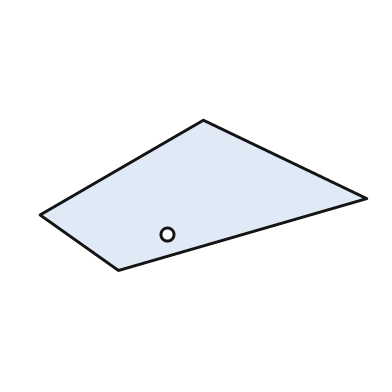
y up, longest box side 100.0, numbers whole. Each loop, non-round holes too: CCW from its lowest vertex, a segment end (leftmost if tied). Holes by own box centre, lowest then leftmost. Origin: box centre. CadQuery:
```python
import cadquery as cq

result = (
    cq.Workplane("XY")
    .moveTo(-26.0, -23.0)
    .lineTo(50.0, -1.0)
    .lineTo(0.0, 23.0)
    .lineTo(-50.0, -6.0)
    .close()
    .moveTo(-11.0, -12.0)
    .circle(2.0)
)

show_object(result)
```